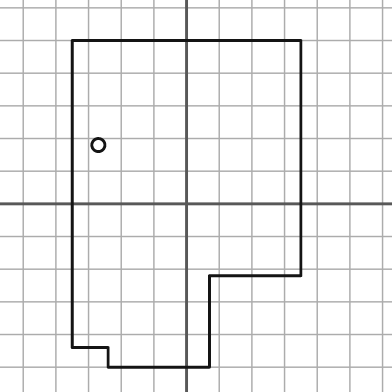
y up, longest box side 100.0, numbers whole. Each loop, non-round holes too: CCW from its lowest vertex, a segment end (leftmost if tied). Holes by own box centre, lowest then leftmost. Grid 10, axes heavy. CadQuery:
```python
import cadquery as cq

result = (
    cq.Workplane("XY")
    .moveTo(-24.0, -50.0)
    .lineTo(7.0, -50.0)
    .lineTo(7.0, -22.0)
    .lineTo(35.0, -22.0)
    .lineTo(35.0, 50.0)
    .lineTo(-35.0, 50.0)
    .lineTo(-35.0, -44.0)
    .lineTo(-24.0, -44.0)
    .close()
    .moveTo(-27.0, 18.0)
    .circle(2.0)
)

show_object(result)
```